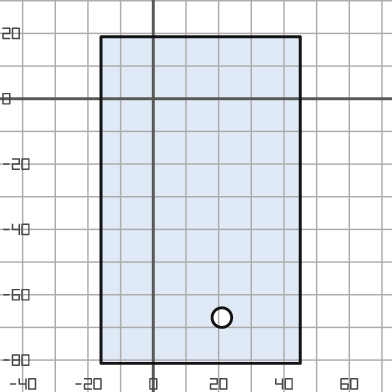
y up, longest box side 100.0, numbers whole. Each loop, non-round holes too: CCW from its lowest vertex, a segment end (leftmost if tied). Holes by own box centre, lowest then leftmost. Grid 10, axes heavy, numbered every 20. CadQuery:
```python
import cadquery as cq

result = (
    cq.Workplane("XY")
    .moveTo(-16.0, -81.0)
    .lineTo(45.0, -81.0)
    .lineTo(45.0, 19.0)
    .lineTo(-16.0, 19.0)
    .close()
    .moveTo(21.0, -67.0)
    .circle(3.0)
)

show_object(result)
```